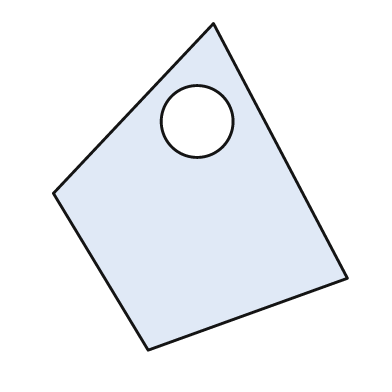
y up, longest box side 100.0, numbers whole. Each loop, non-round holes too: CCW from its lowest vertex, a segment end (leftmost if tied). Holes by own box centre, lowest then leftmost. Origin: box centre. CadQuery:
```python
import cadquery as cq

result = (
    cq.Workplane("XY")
    .moveTo(-16.0, -50.0)
    .lineTo(45.0, -28.0)
    .lineTo(4.0, 50.0)
    .lineTo(-45.0, -2.0)
    .close()
    .moveTo(-1.0, 20.0)
    .circle(11.0)
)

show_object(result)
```